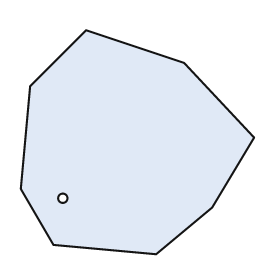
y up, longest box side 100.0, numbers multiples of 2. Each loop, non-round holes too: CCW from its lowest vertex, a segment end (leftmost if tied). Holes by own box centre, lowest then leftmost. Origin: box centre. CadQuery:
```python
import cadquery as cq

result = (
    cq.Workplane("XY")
    .moveTo(8.0, -48.0)
    .lineTo(32.0, -28.0)
    .lineTo(50.0, 2.0)
    .lineTo(20.0, 34.0)
    .lineTo(-22.0, 48.0)
    .lineTo(-46.0, 24.0)
    .lineTo(-50.0, -20.0)
    .lineTo(-36.0, -44.0)
    .close()
    .moveTo(-32.0, -24.0)
    .circle(2.0)
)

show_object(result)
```